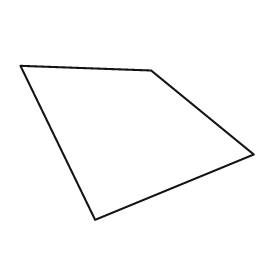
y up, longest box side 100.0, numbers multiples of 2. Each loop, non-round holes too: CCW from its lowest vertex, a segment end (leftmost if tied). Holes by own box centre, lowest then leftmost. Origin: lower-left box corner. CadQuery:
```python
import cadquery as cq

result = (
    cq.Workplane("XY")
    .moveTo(32.0, 0.0)
    .lineTo(100.0, 28.0)
    .lineTo(56.0, 64.0)
    .lineTo(0.0, 66.0)
    .close()
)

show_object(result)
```